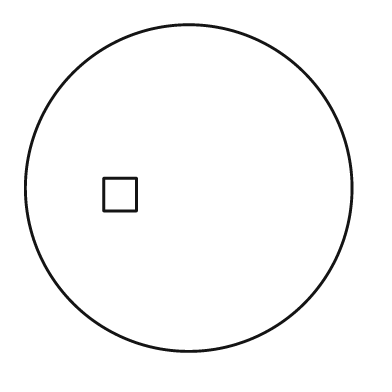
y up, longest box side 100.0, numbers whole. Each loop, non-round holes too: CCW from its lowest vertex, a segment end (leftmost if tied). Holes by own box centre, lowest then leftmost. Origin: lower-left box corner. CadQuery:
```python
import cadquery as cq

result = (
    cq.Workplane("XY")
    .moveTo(50.0, 50.0)
    .circle(50.0)
    .moveTo(24.0, 43.0)
    .lineTo(34.0, 43.0)
    .lineTo(34.0, 53.0)
    .lineTo(24.0, 53.0)
    .close()
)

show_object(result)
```